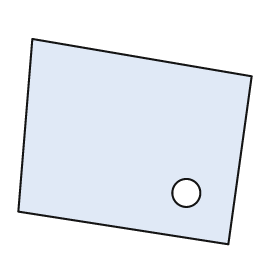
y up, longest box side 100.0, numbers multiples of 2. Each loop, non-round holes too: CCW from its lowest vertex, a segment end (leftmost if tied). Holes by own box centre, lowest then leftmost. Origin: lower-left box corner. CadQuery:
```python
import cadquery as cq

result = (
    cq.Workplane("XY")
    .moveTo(90.0, 0.0)
    .lineTo(100.0, 72.0)
    .lineTo(6.0, 88.0)
    .lineTo(0.0, 14.0)
    .close()
    .moveTo(72.0, 22.0)
    .circle(6.0)
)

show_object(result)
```